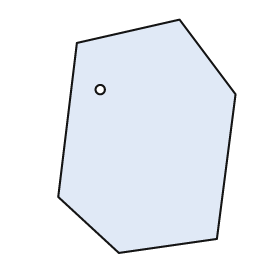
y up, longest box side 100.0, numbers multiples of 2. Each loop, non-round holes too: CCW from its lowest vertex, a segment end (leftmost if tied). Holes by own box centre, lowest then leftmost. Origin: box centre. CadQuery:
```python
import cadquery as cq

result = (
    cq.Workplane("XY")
    .moveTo(-12.0, -50.0)
    .lineTo(30.0, -44.0)
    .lineTo(38.0, 18.0)
    .lineTo(14.0, 50.0)
    .lineTo(-30.0, 40.0)
    .lineTo(-38.0, -26.0)
    .close()
    .moveTo(-20.0, 20.0)
    .circle(2.0)
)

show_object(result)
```